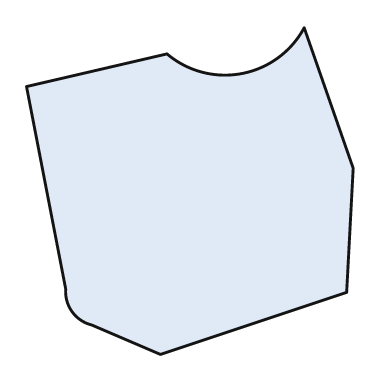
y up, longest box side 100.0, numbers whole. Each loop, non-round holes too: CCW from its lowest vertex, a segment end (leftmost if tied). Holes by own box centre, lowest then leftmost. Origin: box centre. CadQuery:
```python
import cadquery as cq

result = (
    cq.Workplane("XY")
    .moveTo(-9.0, -50.0)
    .lineTo(48.0, -31.0)
    .lineTo(50.0, 7.0)
    .lineTo(35.0, 50.0)
    .threePointArc((16.0, 36.0), (-7.0, 42.0))
    .lineTo(-50.0, 32.0)
    .lineTo(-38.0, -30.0)
    .threePointArc((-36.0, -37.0), (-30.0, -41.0))
    .close()
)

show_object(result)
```